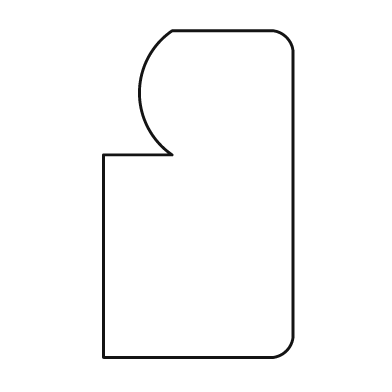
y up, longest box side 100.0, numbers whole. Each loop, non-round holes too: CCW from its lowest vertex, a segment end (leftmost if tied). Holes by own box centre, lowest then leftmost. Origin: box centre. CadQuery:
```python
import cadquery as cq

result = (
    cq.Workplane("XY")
    .moveTo(-29.0, -50.0)
    .lineTo(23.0, -50.0)
    .threePointArc((27.0, -48.0), (29.0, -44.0))
    .lineTo(29.0, 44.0)
    .threePointArc((27.0, 48.0), (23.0, 50.0))
    .lineTo(-8.0, 50.0)
    .threePointArc((-18.0, 31.0), (-8.0, 12.0))
    .lineTo(-29.0, 12.0)
    .close()
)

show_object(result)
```